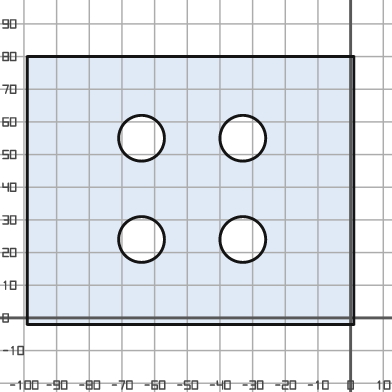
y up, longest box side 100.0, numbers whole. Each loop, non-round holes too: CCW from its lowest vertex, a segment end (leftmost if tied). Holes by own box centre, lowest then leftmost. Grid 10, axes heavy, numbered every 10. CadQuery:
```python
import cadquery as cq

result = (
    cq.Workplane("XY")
    .moveTo(-99.0, -2.0)
    .lineTo(1.0, -2.0)
    .lineTo(1.0, 80.0)
    .lineTo(-99.0, 80.0)
    .close()
    .moveTo(-64.0, 24.0)
    .circle(7.0)
    .moveTo(-33.0, 24.0)
    .circle(7.0)
    .moveTo(-64.0, 55.0)
    .circle(7.0)
    .moveTo(-33.0, 55.0)
    .circle(7.0)
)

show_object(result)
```